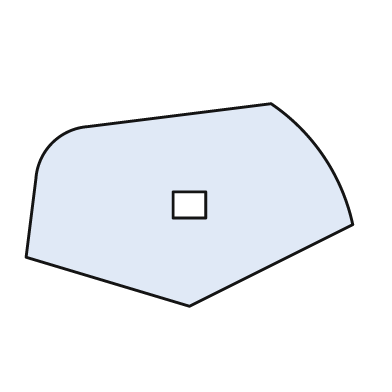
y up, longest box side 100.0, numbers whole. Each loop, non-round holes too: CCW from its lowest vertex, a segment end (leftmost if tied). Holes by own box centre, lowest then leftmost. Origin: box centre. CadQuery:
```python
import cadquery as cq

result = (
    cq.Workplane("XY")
    .moveTo(0.0, -31.0)
    .lineTo(50.0, -6.0)
    .threePointArc((41.0, 15.0), (25.0, 31.0))
    .lineTo(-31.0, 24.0)
    .threePointArc((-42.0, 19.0), (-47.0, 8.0))
    .lineTo(-50.0, -16.0)
    .close()
    .moveTo(-5.0, -4.0)
    .lineTo(5.0, -4.0)
    .lineTo(5.0, 4.0)
    .lineTo(-5.0, 4.0)
    .close()
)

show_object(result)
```